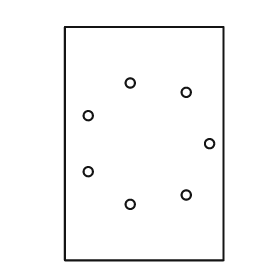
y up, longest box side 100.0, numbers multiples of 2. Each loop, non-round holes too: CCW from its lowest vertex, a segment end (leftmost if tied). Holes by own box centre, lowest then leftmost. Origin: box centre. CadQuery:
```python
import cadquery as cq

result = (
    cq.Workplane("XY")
    .moveTo(-34.0, -50.0)
    .lineTo(34.0, -50.0)
    .lineTo(34.0, 50.0)
    .lineTo(-34.0, 50.0)
    .close()
    .moveTo(-6.0, -26.0)
    .circle(2.0)
    .moveTo(18.0, -22.0)
    .circle(2.0)
    .moveTo(-24.0, -12.0)
    .circle(2.0)
    .moveTo(28.0, 0.0)
    .circle(2.0)
    .moveTo(-24.0, 12.0)
    .circle(2.0)
    .moveTo(18.0, 22.0)
    .circle(2.0)
    .moveTo(-6.0, 26.0)
    .circle(2.0)
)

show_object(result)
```